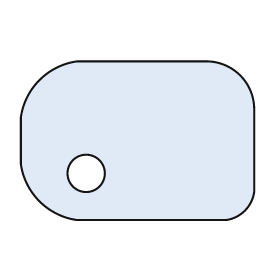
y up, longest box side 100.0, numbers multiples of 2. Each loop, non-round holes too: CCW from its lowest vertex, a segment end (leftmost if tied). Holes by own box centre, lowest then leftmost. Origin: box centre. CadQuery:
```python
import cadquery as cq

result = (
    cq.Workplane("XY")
    .moveTo(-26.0, -34.0)
    .lineTo(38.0, -34.0)
    .threePointArc((46.0, -30.0), (50.0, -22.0))
    .lineTo(50.0, 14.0)
    .threePointArc((44.0, 28.0), (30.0, 34.0))
    .lineTo(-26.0, 34.0)
    .threePointArc((-42.0, 26.0), (-50.0, 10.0))
    .lineTo(-50.0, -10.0)
    .threePointArc((-42.0, -26.0), (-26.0, -34.0))
    .close()
    .moveTo(-22.0, -14.0)
    .circle(8.0)
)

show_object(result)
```